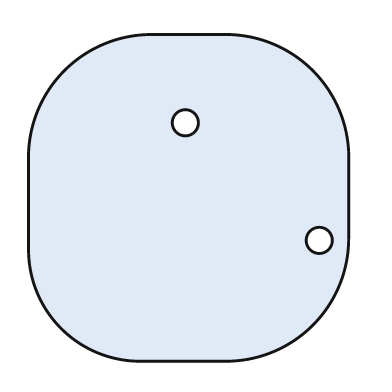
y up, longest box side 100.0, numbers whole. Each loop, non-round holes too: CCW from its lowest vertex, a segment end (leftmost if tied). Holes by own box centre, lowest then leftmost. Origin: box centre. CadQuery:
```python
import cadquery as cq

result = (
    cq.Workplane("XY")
    .moveTo(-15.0, -50.0)
    .lineTo(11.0, -50.0)
    .threePointArc((38.0, -39.0), (49.0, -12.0))
    .lineTo(49.0, 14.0)
    .threePointArc((38.0, 39.0), (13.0, 50.0))
    .lineTo(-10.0, 50.0)
    .threePointArc((-38.0, 39.0), (-49.0, 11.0))
    .lineTo(-49.0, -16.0)
    .threePointArc((-39.0, -40.0), (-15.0, -50.0))
    .close()
    .moveTo(40.0, -13.0)
    .circle(4.0)
    .moveTo(-1.0, 23.0)
    .circle(4.0)
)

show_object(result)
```